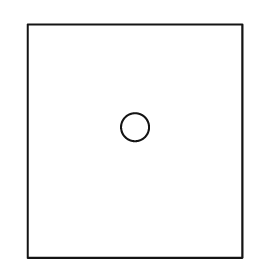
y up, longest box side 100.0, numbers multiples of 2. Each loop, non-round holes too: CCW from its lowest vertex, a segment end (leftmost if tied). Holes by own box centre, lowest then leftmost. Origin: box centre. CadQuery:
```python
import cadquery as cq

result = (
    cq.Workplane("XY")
    .moveTo(-46.0, -50.0)
    .lineTo(46.0, -50.0)
    .lineTo(46.0, 50.0)
    .lineTo(-46.0, 50.0)
    .close()
    .moveTo(0.0, 6.0)
    .circle(6.0)
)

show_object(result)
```